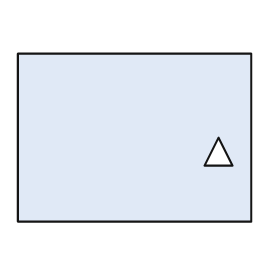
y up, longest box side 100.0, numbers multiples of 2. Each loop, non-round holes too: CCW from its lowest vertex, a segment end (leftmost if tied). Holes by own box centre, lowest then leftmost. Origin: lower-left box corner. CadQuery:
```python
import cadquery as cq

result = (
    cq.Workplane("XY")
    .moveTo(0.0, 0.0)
    .lineTo(100.0, 0.0)
    .lineTo(100.0, 72.0)
    .lineTo(0.0, 72.0)
    .close()
    .moveTo(80.0, 24.0)
    .lineTo(92.0, 24.0)
    .lineTo(86.0, 36.0)
    .close()
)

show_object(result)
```